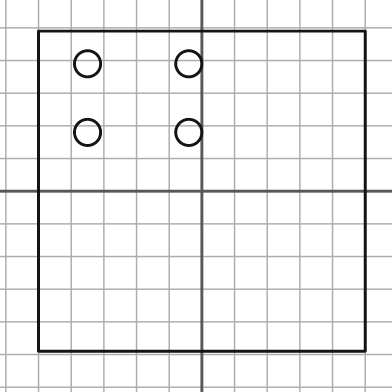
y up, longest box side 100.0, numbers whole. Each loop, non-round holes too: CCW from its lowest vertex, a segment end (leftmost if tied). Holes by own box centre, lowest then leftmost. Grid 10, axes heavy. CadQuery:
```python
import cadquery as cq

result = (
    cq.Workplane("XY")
    .moveTo(-50.0, -49.0)
    .lineTo(50.0, -49.0)
    .lineTo(50.0, 49.0)
    .lineTo(-50.0, 49.0)
    .close()
    .moveTo(-35.0, 18.0)
    .circle(4.0)
    .moveTo(-4.0, 18.0)
    .circle(4.0)
    .moveTo(-35.0, 39.0)
    .circle(4.0)
    .moveTo(-4.0, 39.0)
    .circle(4.0)
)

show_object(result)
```